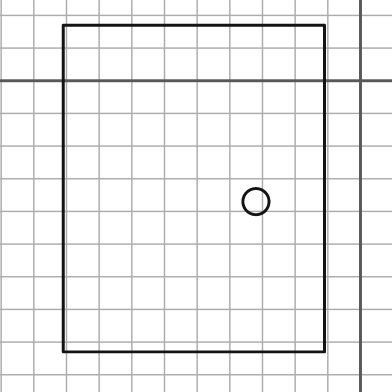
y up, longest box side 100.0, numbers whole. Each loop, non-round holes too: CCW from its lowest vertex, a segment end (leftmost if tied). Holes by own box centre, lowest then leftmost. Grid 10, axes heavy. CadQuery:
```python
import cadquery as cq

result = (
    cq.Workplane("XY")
    .moveTo(-91.0, -83.0)
    .lineTo(-11.0, -83.0)
    .lineTo(-11.0, 17.0)
    .lineTo(-91.0, 17.0)
    .close()
    .moveTo(-32.0, -37.0)
    .circle(4.0)
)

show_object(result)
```